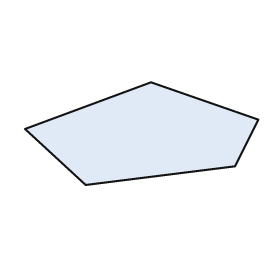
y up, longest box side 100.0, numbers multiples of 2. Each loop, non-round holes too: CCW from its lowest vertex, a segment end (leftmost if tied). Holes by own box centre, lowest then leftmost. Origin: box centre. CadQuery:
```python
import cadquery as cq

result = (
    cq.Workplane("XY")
    .moveTo(-24.0, -22.0)
    .lineTo(40.0, -14.0)
    .lineTo(50.0, 6.0)
    .lineTo(4.0, 22.0)
    .lineTo(-50.0, 2.0)
    .close()
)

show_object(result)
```